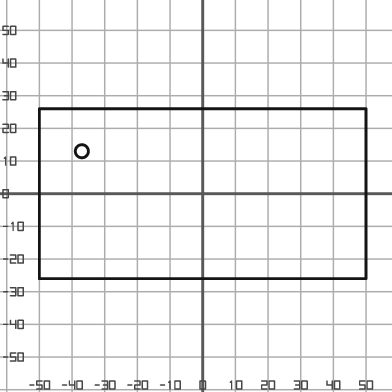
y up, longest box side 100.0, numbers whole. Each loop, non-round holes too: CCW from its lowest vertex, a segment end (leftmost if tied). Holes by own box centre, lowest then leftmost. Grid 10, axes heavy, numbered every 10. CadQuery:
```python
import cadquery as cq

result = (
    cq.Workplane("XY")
    .moveTo(-50.0, -26.0)
    .lineTo(50.0, -26.0)
    .lineTo(50.0, 26.0)
    .lineTo(-50.0, 26.0)
    .close()
    .moveTo(-37.0, 13.0)
    .circle(2.0)
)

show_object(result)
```